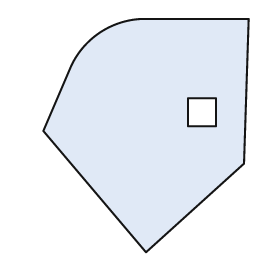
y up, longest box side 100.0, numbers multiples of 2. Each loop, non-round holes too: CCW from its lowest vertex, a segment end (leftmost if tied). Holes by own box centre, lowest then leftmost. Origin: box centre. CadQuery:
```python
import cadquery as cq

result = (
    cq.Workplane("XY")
    .moveTo(0.0, -50.0)
    .lineTo(42.0, -12.0)
    .lineTo(44.0, 50.0)
    .lineTo(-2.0, 50.0)
    .threePointArc((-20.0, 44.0), (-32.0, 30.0))
    .lineTo(-44.0, 2.0)
    .close()
    .moveTo(18.0, 4.0)
    .lineTo(30.0, 4.0)
    .lineTo(30.0, 16.0)
    .lineTo(18.0, 16.0)
    .close()
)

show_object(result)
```